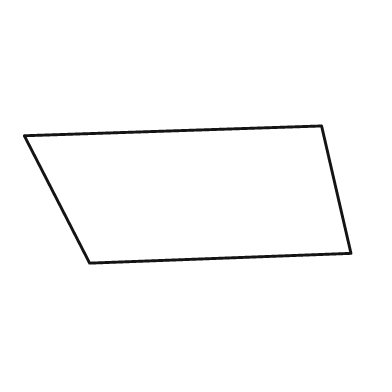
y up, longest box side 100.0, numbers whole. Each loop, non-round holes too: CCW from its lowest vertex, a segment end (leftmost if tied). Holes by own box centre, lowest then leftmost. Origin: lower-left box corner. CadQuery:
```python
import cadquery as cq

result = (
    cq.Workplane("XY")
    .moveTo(20.0, 0.0)
    .lineTo(100.0, 3.0)
    .lineTo(91.0, 42.0)
    .lineTo(0.0, 39.0)
    .close()
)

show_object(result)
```